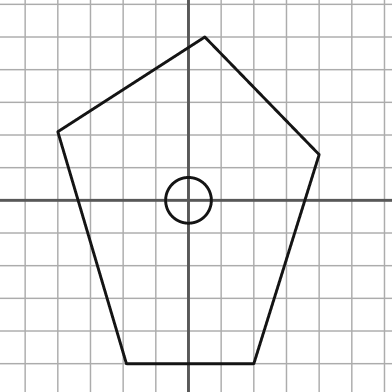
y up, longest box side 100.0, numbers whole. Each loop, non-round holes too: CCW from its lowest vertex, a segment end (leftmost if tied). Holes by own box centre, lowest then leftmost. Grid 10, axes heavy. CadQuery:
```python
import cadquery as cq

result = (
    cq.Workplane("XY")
    .moveTo(-19.0, -50.0)
    .lineTo(20.0, -50.0)
    .lineTo(40.0, 14.0)
    .lineTo(5.0, 50.0)
    .lineTo(-40.0, 21.0)
    .close()
    .moveTo(0.0, 0.0)
    .circle(7.0)
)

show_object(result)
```